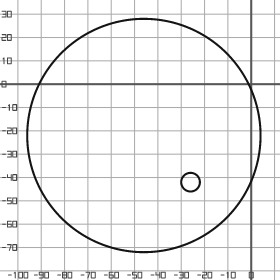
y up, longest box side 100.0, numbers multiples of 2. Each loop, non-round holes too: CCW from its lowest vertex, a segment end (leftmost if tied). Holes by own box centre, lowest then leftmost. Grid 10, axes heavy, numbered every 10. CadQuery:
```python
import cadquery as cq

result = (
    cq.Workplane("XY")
    .moveTo(-46.0, -22.0)
    .circle(50.0)
    .moveTo(-26.0, -42.0)
    .circle(4.0)
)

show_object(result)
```